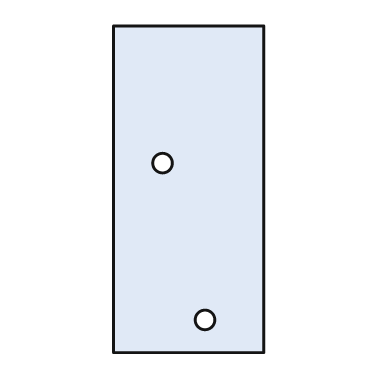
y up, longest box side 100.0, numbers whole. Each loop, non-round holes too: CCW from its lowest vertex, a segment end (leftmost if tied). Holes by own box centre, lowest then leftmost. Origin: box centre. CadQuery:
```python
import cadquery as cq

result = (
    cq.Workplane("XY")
    .moveTo(-23.0, -50.0)
    .lineTo(23.0, -50.0)
    .lineTo(23.0, 50.0)
    .lineTo(-23.0, 50.0)
    .close()
    .moveTo(5.0, -40.0)
    .circle(3.0)
    .moveTo(-8.0, 8.0)
    .circle(3.0)
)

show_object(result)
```